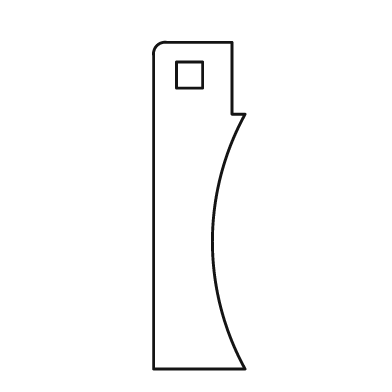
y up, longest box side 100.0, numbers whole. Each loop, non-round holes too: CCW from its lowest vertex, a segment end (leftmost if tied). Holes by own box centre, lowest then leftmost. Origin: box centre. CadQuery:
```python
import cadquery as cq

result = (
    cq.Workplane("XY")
    .moveTo(-14.0, -50.0)
    .lineTo(14.0, -50.0)
    .threePointArc((4.0, -11.0), (14.0, 28.0))
    .lineTo(10.0, 28.0)
    .lineTo(10.0, 50.0)
    .lineTo(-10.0, 50.0)
    .threePointArc((-13.0, 49.0), (-14.0, 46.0))
    .close()
    .moveTo(-7.0, 36.0)
    .lineTo(1.0, 36.0)
    .lineTo(1.0, 44.0)
    .lineTo(-7.0, 44.0)
    .close()
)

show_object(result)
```